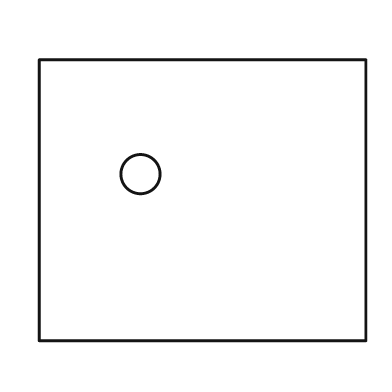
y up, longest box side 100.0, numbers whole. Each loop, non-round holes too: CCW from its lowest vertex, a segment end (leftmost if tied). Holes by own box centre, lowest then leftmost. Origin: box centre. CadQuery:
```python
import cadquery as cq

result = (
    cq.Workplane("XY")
    .moveTo(-50.0, -43.0)
    .lineTo(50.0, -43.0)
    .lineTo(50.0, 43.0)
    .lineTo(-50.0, 43.0)
    .close()
    .moveTo(-19.0, 8.0)
    .circle(6.0)
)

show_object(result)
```